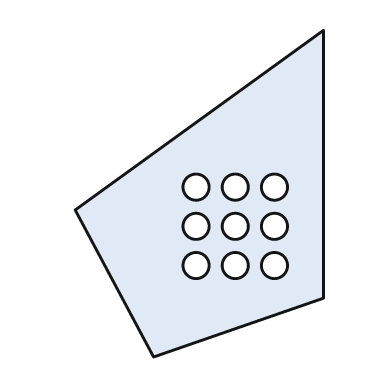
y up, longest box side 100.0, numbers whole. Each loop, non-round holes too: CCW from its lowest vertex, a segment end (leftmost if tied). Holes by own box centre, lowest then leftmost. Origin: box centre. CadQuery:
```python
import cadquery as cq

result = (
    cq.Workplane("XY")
    .moveTo(-14.0, -50.0)
    .lineTo(38.0, -32.0)
    .lineTo(38.0, 50.0)
    .lineTo(-38.0, -5.0)
    .close()
    .moveTo(-1.0, -22.0)
    .circle(4.0)
    .moveTo(11.0, -22.0)
    .circle(4.0)
    .moveTo(23.0, -22.0)
    .circle(4.0)
    .moveTo(-1.0, -10.0)
    .circle(4.0)
    .moveTo(11.0, -10.0)
    .circle(4.0)
    .moveTo(23.0, -10.0)
    .circle(4.0)
    .moveTo(-1.0, 2.0)
    .circle(4.0)
    .moveTo(11.0, 2.0)
    .circle(4.0)
    .moveTo(23.0, 2.0)
    .circle(4.0)
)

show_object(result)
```